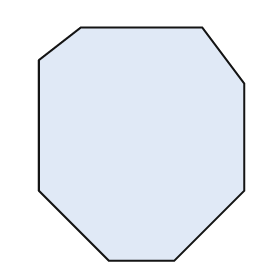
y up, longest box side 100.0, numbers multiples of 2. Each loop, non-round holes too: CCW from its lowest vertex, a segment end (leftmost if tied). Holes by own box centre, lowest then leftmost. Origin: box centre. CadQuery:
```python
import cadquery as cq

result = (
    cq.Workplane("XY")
    .moveTo(-14.0, -50.0)
    .lineTo(14.0, -50.0)
    .lineTo(44.0, -20.0)
    .lineTo(44.0, 26.0)
    .lineTo(26.0, 50.0)
    .lineTo(-26.0, 50.0)
    .lineTo(-44.0, 36.0)
    .lineTo(-44.0, -20.0)
    .close()
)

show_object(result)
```